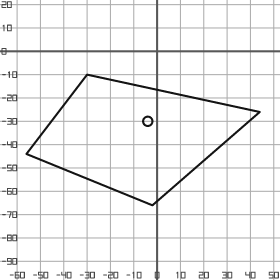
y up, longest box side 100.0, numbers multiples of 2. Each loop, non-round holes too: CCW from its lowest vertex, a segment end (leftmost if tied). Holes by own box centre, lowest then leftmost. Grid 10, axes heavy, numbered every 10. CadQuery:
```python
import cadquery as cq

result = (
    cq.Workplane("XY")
    .moveTo(-2.0, -66.0)
    .lineTo(44.0, -26.0)
    .lineTo(-30.0, -10.0)
    .lineTo(-56.0, -44.0)
    .close()
    .moveTo(-4.0, -30.0)
    .circle(2.0)
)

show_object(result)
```